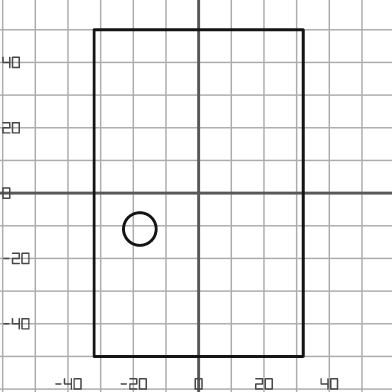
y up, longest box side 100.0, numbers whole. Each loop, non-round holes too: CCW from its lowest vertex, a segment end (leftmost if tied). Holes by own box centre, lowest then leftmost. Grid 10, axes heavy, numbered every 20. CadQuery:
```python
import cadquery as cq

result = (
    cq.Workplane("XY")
    .moveTo(-32.0, -50.0)
    .lineTo(32.0, -50.0)
    .lineTo(32.0, 50.0)
    .lineTo(-32.0, 50.0)
    .close()
    .moveTo(-18.0, -11.0)
    .circle(5.0)
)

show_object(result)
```